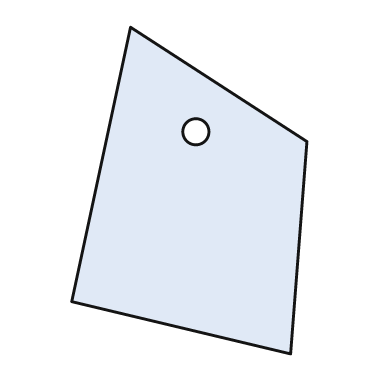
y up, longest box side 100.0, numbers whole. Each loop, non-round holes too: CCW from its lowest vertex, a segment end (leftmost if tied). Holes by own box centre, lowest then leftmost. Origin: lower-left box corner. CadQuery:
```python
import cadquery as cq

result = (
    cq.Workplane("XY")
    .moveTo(67.0, 0.0)
    .lineTo(72.0, 65.0)
    .lineTo(18.0, 100.0)
    .lineTo(0.0, 16.0)
    .close()
    .moveTo(38.0, 68.0)
    .circle(4.0)
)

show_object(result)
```